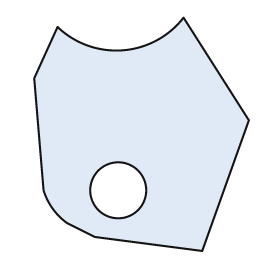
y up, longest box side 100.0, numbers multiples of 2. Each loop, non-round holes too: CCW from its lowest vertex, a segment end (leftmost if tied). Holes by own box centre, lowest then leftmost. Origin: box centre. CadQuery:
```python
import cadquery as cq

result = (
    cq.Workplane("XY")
    .moveTo(26.0, -50.0)
    .lineTo(46.0, 6.0)
    .lineTo(18.0, 50.0)
    .threePointArc((-8.0, 36.0), (-36.0, 46.0))
    .lineTo(-46.0, 24.0)
    .lineTo(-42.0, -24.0)
    .threePointArc((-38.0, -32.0), (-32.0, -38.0))
    .lineTo(-20.0, -44.0)
    .close()
    .moveTo(-10.0, -24.0)
    .circle(12.0)
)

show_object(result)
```